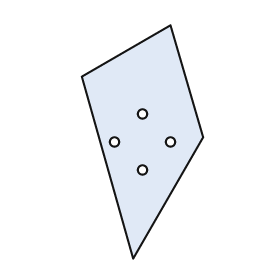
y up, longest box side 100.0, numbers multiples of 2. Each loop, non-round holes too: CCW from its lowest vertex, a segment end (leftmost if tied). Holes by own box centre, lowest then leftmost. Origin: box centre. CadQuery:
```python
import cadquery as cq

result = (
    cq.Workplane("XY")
    .moveTo(-4.0, -50.0)
    .lineTo(26.0, 2.0)
    .lineTo(12.0, 50.0)
    .lineTo(-26.0, 28.0)
    .close()
    .moveTo(0.0, -12.0)
    .circle(2.0)
    .moveTo(-12.0, 0.0)
    .circle(2.0)
    .moveTo(12.0, 0.0)
    .circle(2.0)
    .moveTo(0.0, 12.0)
    .circle(2.0)
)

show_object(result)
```